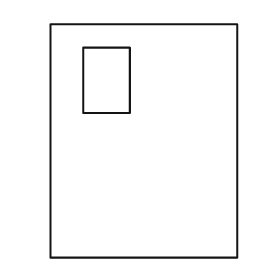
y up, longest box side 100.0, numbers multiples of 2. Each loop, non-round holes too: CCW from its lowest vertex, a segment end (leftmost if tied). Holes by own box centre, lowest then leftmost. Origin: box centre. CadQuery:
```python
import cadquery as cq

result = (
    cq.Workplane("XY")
    .moveTo(-40.0, -50.0)
    .lineTo(40.0, -50.0)
    .lineTo(40.0, 50.0)
    .lineTo(-40.0, 50.0)
    .close()
    .moveTo(-26.0, 12.0)
    .lineTo(-6.0, 12.0)
    .lineTo(-6.0, 40.0)
    .lineTo(-26.0, 40.0)
    .close()
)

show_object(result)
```